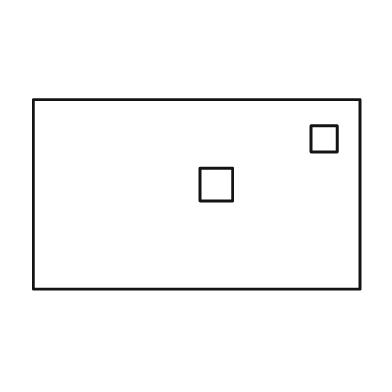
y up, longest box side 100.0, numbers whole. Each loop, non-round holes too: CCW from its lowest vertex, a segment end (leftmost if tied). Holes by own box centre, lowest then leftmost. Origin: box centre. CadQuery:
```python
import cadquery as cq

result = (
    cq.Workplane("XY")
    .moveTo(-50.0, -29.0)
    .lineTo(50.0, -29.0)
    .lineTo(50.0, 29.0)
    .lineTo(-50.0, 29.0)
    .close()
    .moveTo(1.0, -2.0)
    .lineTo(11.0, -2.0)
    .lineTo(11.0, 8.0)
    .lineTo(1.0, 8.0)
    .close()
    .moveTo(35.0, 13.0)
    .lineTo(43.0, 13.0)
    .lineTo(43.0, 21.0)
    .lineTo(35.0, 21.0)
    .close()
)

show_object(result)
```